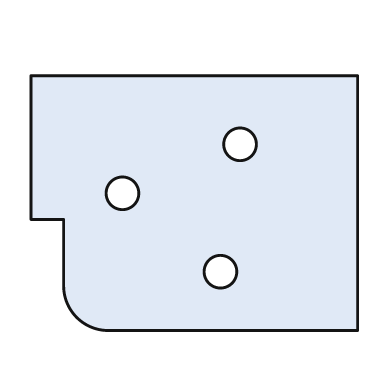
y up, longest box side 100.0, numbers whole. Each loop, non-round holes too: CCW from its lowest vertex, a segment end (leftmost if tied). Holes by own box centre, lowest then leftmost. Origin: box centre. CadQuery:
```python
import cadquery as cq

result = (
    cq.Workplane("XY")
    .moveTo(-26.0, -39.0)
    .lineTo(50.0, -39.0)
    .lineTo(50.0, 39.0)
    .lineTo(-50.0, 39.0)
    .lineTo(-50.0, -5.0)
    .lineTo(-40.0, -5.0)
    .lineTo(-40.0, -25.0)
    .threePointArc((-36.0, -35.0), (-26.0, -39.0))
    .close()
    .moveTo(8.0, -21.0)
    .circle(5.0)
    .moveTo(-22.0, 3.0)
    .circle(5.0)
    .moveTo(14.0, 18.0)
    .circle(5.0)
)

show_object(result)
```